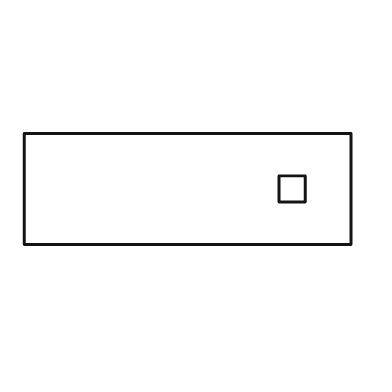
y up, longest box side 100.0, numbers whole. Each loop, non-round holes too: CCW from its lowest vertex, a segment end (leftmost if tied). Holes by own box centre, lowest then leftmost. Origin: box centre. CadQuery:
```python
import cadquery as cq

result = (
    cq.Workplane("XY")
    .moveTo(-50.0, -17.0)
    .lineTo(50.0, -17.0)
    .lineTo(50.0, 17.0)
    .lineTo(-50.0, 17.0)
    .close()
    .moveTo(28.0, -4.0)
    .lineTo(36.0, -4.0)
    .lineTo(36.0, 4.0)
    .lineTo(28.0, 4.0)
    .close()
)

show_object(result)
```